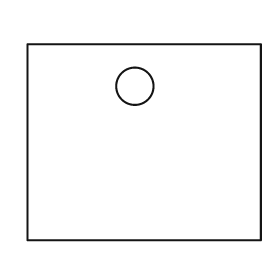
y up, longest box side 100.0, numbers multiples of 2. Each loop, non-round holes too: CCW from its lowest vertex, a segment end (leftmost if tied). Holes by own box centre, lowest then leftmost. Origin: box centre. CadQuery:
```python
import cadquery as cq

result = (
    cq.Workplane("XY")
    .moveTo(-50.0, -42.0)
    .lineTo(50.0, -42.0)
    .lineTo(50.0, 42.0)
    .lineTo(-50.0, 42.0)
    .close()
    .moveTo(-4.0, 24.0)
    .circle(8.0)
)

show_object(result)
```